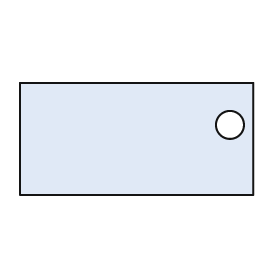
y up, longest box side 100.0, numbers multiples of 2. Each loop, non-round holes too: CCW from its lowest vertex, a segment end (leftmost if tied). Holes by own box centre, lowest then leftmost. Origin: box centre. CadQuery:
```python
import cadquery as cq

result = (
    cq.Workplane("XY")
    .moveTo(-50.0, -24.0)
    .lineTo(50.0, -24.0)
    .lineTo(50.0, 24.0)
    .lineTo(-50.0, 24.0)
    .close()
    .moveTo(40.0, 6.0)
    .circle(6.0)
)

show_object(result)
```